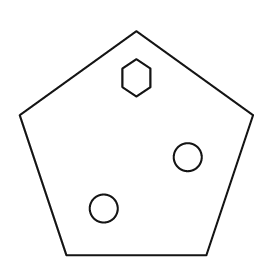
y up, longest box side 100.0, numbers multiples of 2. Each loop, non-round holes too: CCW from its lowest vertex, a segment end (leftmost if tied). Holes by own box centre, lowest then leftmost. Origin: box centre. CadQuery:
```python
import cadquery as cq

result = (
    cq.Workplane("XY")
    .moveTo(-30.0, -48.0)
    .lineTo(30.0, -48.0)
    .lineTo(50.0, 12.0)
    .lineTo(0.0, 48.0)
    .lineTo(-50.0, 12.0)
    .close()
    .moveTo(-14.0, -28.0)
    .circle(6.0)
    .moveTo(22.0, -6.0)
    .circle(6.0)
    .moveTo(0.0, 20.0)
    .lineTo(6.0, 24.0)
    .lineTo(6.0, 32.0)
    .lineTo(0.0, 36.0)
    .lineTo(-6.0, 32.0)
    .lineTo(-6.0, 24.0)
    .close()
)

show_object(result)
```